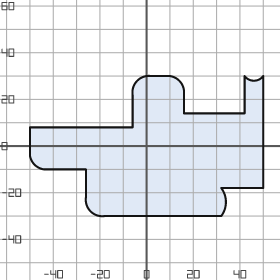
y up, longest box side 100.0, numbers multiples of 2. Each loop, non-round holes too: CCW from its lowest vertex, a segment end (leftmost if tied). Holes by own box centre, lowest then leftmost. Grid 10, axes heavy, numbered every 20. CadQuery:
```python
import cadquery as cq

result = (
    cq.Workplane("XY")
    .moveTo(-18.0, -30.0)
    .lineTo(32.0, -30.0)
    .threePointArc((34.0, -24.0), (32.0, -18.0))
    .lineTo(50.0, -18.0)
    .lineTo(50.0, 30.0)
    .threePointArc((46.0, 28.0), (42.0, 30.0))
    .lineTo(42.0, 14.0)
    .lineTo(16.0, 14.0)
    .lineTo(16.0, 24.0)
    .threePointArc((14.0, 28.0), (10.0, 30.0))
    .lineTo(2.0, 30.0)
    .threePointArc((-4.0, 28.0), (-6.0, 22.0))
    .lineTo(-6.0, 8.0)
    .lineTo(-50.0, 8.0)
    .lineTo(-50.0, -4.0)
    .threePointArc((-48.0, -8.0), (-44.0, -10.0))
    .lineTo(-26.0, -10.0)
    .lineTo(-26.0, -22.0)
    .threePointArc((-24.0, -28.0), (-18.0, -30.0))
    .close()
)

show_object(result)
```